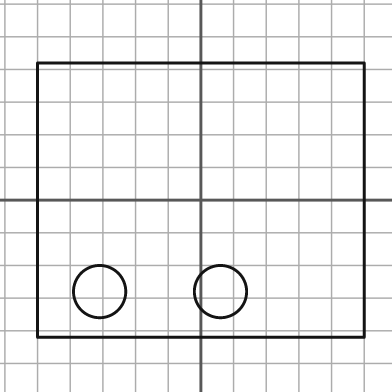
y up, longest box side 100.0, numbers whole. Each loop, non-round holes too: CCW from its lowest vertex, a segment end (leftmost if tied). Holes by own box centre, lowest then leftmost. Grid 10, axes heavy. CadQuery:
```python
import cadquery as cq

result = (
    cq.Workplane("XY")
    .moveTo(-50.0, -42.0)
    .lineTo(50.0, -42.0)
    .lineTo(50.0, 42.0)
    .lineTo(-50.0, 42.0)
    .close()
    .moveTo(-31.0, -28.0)
    .circle(8.0)
    .moveTo(6.0, -28.0)
    .circle(8.0)
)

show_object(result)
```